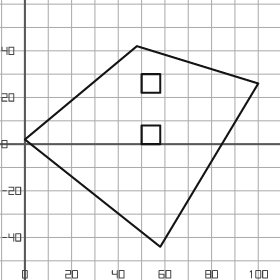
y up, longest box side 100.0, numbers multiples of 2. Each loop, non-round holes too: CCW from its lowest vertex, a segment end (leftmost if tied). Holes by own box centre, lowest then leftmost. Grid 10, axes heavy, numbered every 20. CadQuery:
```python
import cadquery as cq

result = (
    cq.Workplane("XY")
    .moveTo(58.0, -44.0)
    .lineTo(100.0, 26.0)
    .lineTo(48.0, 42.0)
    .lineTo(0.0, 2.0)
    .close()
    .moveTo(50.0, 0.0)
    .lineTo(58.0, 0.0)
    .lineTo(58.0, 8.0)
    .lineTo(50.0, 8.0)
    .close()
    .moveTo(50.0, 22.0)
    .lineTo(58.0, 22.0)
    .lineTo(58.0, 30.0)
    .lineTo(50.0, 30.0)
    .close()
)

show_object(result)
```